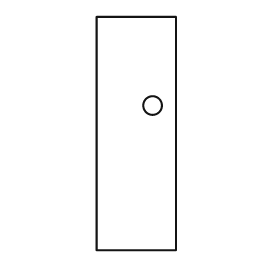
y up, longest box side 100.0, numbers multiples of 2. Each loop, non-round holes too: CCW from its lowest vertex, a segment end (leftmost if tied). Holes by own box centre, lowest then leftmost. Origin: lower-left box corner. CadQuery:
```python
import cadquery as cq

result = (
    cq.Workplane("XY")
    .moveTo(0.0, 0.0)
    .lineTo(34.0, 0.0)
    .lineTo(34.0, 100.0)
    .lineTo(0.0, 100.0)
    .close()
    .moveTo(24.0, 62.0)
    .circle(4.0)
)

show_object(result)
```